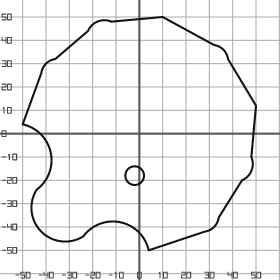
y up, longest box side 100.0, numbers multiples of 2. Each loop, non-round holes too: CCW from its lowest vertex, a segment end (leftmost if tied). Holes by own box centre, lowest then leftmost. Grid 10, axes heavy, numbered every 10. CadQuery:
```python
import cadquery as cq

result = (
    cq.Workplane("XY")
    .moveTo(4.0, -50.0)
    .lineTo(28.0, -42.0)
    .threePointArc((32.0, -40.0), (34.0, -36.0))
    .lineTo(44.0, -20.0)
    .threePointArc((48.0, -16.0), (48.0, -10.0))
    .lineTo(50.0, 12.0)
    .lineTo(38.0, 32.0)
    .threePointArc((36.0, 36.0), (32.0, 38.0))
    .lineTo(10.0, 50.0)
    .lineTo(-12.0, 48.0)
    .threePointArc((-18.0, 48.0), (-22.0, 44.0))
    .lineTo(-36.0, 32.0)
    .threePointArc((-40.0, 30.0), (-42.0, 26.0))
    .lineTo(-50.0, 4.0)
    .threePointArc((-38.0, -8.0), (-44.0, -24.0))
    .threePointArc((-42.0, -42.0), (-24.0, -44.0))
    .threePointArc((-8.0, -38.0), (4.0, -50.0))
    .close()
    .moveTo(-2.0, -18.0)
    .circle(4.0)
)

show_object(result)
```